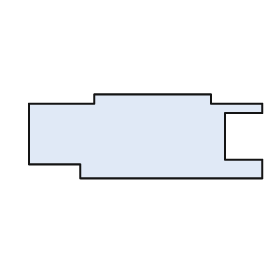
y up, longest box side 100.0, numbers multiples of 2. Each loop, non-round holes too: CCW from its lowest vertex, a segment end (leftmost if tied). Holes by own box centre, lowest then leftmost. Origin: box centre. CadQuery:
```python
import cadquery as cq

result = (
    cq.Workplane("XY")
    .moveTo(-28.0, -18.0)
    .lineTo(50.0, -18.0)
    .lineTo(50.0, -10.0)
    .lineTo(34.0, -10.0)
    .lineTo(34.0, 10.0)
    .lineTo(50.0, 10.0)
    .lineTo(50.0, 14.0)
    .lineTo(28.0, 14.0)
    .lineTo(28.0, 18.0)
    .lineTo(-22.0, 18.0)
    .lineTo(-22.0, 14.0)
    .lineTo(-50.0, 14.0)
    .lineTo(-50.0, -12.0)
    .lineTo(-28.0, -12.0)
    .close()
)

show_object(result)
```